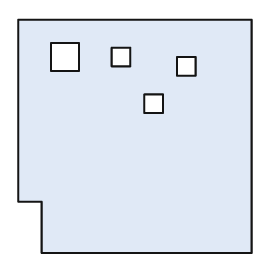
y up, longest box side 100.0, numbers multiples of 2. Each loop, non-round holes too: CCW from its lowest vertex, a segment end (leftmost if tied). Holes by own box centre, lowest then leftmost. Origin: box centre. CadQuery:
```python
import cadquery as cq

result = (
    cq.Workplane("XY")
    .moveTo(-40.0, -50.0)
    .lineTo(50.0, -50.0)
    .lineTo(50.0, 50.0)
    .lineTo(-50.0, 50.0)
    .lineTo(-50.0, -28.0)
    .lineTo(-40.0, -28.0)
    .close()
    .moveTo(4.0, 10.0)
    .lineTo(12.0, 10.0)
    .lineTo(12.0, 18.0)
    .lineTo(4.0, 18.0)
    .close()
    .moveTo(18.0, 26.0)
    .lineTo(26.0, 26.0)
    .lineTo(26.0, 34.0)
    .lineTo(18.0, 34.0)
    .close()
    .moveTo(-36.0, 28.0)
    .lineTo(-24.0, 28.0)
    .lineTo(-24.0, 40.0)
    .lineTo(-36.0, 40.0)
    .close()
    .moveTo(-10.0, 30.0)
    .lineTo(-2.0, 30.0)
    .lineTo(-2.0, 38.0)
    .lineTo(-10.0, 38.0)
    .close()
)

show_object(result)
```